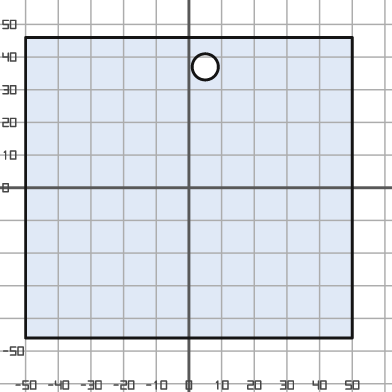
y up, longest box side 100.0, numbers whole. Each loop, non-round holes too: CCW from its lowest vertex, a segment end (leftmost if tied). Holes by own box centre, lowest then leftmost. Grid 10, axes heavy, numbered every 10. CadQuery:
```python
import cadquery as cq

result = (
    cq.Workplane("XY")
    .moveTo(-50.0, -46.0)
    .lineTo(50.0, -46.0)
    .lineTo(50.0, 46.0)
    .lineTo(-50.0, 46.0)
    .close()
    .moveTo(5.0, 37.0)
    .circle(4.0)
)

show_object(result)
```